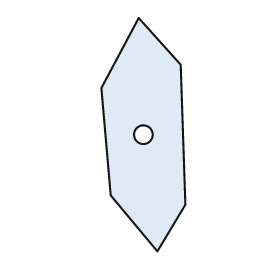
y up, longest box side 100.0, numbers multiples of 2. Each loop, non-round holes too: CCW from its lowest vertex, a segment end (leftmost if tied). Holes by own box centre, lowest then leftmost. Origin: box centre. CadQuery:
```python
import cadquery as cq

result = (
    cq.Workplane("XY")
    .moveTo(6.0, -50.0)
    .lineTo(18.0, -30.0)
    .lineTo(16.0, 30.0)
    .lineTo(-2.0, 50.0)
    .lineTo(-18.0, 20.0)
    .lineTo(-14.0, -26.0)
    .close()
    .moveTo(0.0, 0.0)
    .circle(4.0)
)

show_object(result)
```